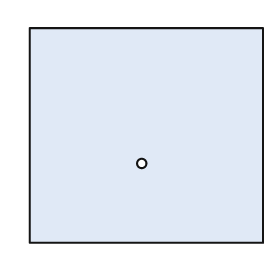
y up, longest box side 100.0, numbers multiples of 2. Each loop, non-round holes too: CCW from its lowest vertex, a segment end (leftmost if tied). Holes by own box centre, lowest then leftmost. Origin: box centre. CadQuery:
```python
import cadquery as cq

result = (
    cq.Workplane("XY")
    .moveTo(-50.0, -46.0)
    .lineTo(50.0, -46.0)
    .lineTo(50.0, 46.0)
    .lineTo(-50.0, 46.0)
    .close()
    .moveTo(-2.0, -12.0)
    .circle(2.0)
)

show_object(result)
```